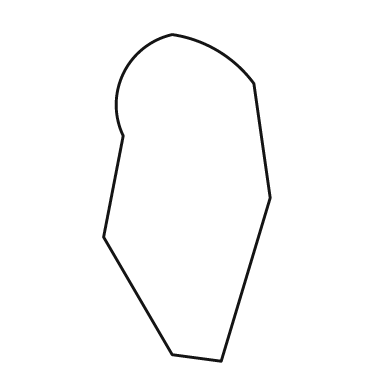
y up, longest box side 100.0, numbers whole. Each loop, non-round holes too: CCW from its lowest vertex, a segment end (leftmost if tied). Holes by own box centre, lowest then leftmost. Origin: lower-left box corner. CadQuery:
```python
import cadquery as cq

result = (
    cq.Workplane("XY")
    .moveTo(36.0, 0.0)
    .lineTo(51.0, 50.0)
    .lineTo(46.0, 85.0)
    .threePointArc((35.0, 95.0), (21.0, 100.0))
    .threePointArc((6.0, 88.0), (6.0, 69.0))
    .lineTo(0.0, 38.0)
    .lineTo(21.0, 2.0)
    .close()
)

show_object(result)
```